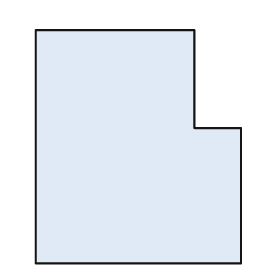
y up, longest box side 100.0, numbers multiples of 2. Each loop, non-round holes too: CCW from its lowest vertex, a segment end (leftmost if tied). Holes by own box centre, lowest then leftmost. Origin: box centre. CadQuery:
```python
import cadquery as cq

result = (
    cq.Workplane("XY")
    .moveTo(-44.0, -50.0)
    .lineTo(44.0, -50.0)
    .lineTo(44.0, 8.0)
    .lineTo(24.0, 8.0)
    .lineTo(24.0, 50.0)
    .lineTo(-44.0, 50.0)
    .close()
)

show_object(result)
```